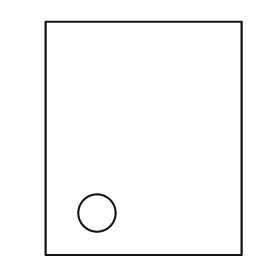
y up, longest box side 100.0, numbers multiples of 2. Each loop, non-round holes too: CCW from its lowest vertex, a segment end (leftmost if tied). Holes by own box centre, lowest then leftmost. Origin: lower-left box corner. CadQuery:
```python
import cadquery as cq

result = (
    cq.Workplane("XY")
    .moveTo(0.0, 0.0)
    .lineTo(84.0, 0.0)
    .lineTo(84.0, 100.0)
    .lineTo(0.0, 100.0)
    .close()
    .moveTo(22.0, 18.0)
    .circle(8.0)
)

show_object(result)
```